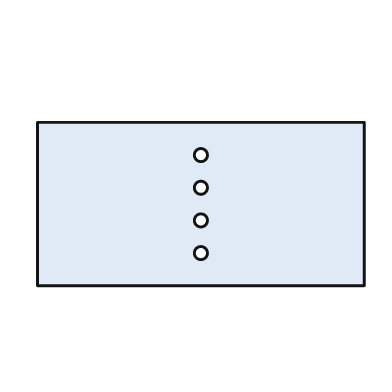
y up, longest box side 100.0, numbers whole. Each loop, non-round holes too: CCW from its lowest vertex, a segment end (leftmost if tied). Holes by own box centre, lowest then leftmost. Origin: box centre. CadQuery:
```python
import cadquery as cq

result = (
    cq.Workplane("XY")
    .moveTo(-50.0, -25.0)
    .lineTo(50.0, -25.0)
    .lineTo(50.0, 25.0)
    .lineTo(-50.0, 25.0)
    .close()
    .moveTo(0.0, -15.0)
    .circle(2.0)
    .moveTo(0.0, -5.0)
    .circle(2.0)
    .moveTo(0.0, 5.0)
    .circle(2.0)
    .moveTo(0.0, 15.0)
    .circle(2.0)
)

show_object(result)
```